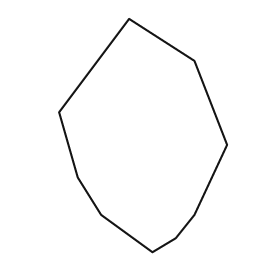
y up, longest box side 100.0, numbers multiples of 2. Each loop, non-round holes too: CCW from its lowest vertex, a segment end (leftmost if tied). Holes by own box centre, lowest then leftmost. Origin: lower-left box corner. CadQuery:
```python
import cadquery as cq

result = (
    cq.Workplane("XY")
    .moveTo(40.0, 0.0)
    .lineTo(50.0, 6.0)
    .lineTo(58.0, 16.0)
    .lineTo(72.0, 46.0)
    .lineTo(58.0, 82.0)
    .lineTo(30.0, 100.0)
    .lineTo(0.0, 60.0)
    .lineTo(8.0, 32.0)
    .lineTo(18.0, 16.0)
    .close()
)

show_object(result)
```